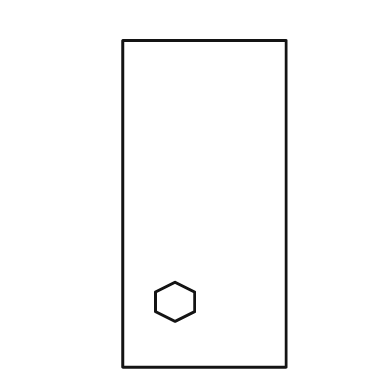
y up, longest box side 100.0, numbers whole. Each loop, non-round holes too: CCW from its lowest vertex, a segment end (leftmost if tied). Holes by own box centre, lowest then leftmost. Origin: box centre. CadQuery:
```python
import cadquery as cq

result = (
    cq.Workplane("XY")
    .moveTo(-25.0, -50.0)
    .lineTo(25.0, -50.0)
    .lineTo(25.0, 50.0)
    .lineTo(-25.0, 50.0)
    .close()
    .moveTo(-9.0, -36.0)
    .lineTo(-3.0, -33.0)
    .lineTo(-3.0, -27.0)
    .lineTo(-9.0, -24.0)
    .lineTo(-15.0, -27.0)
    .lineTo(-15.0, -33.0)
    .close()
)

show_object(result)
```